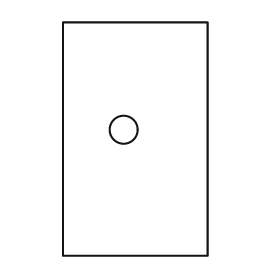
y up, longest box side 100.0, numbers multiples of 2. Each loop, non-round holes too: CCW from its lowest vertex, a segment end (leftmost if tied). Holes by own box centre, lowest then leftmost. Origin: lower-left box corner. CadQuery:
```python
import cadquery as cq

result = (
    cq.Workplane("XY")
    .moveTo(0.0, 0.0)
    .lineTo(62.0, 0.0)
    .lineTo(62.0, 100.0)
    .lineTo(0.0, 100.0)
    .close()
    .moveTo(26.0, 54.0)
    .circle(6.0)
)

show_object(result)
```